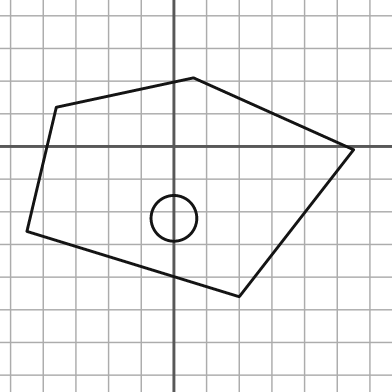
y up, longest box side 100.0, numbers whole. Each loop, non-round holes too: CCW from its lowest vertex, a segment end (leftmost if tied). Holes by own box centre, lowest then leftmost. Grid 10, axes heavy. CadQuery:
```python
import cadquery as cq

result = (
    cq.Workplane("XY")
    .moveTo(20.0, -46.0)
    .lineTo(55.0, -1.0)
    .lineTo(6.0, 21.0)
    .lineTo(-36.0, 12.0)
    .lineTo(-45.0, -26.0)
    .close()
    .moveTo(0.0, -22.0)
    .circle(7.0)
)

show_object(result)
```